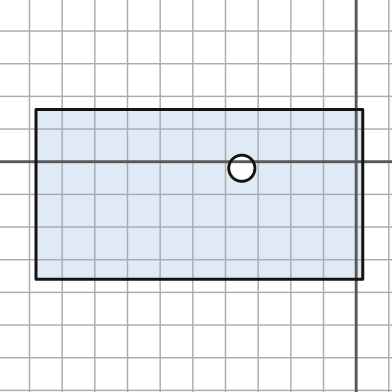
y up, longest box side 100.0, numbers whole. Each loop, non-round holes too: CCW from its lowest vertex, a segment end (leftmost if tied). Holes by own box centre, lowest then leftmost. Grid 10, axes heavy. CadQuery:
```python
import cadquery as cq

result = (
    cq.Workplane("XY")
    .moveTo(-98.0, -36.0)
    .lineTo(2.0, -36.0)
    .lineTo(2.0, 16.0)
    .lineTo(-98.0, 16.0)
    .close()
    .moveTo(-35.0, -2.0)
    .circle(4.0)
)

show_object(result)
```